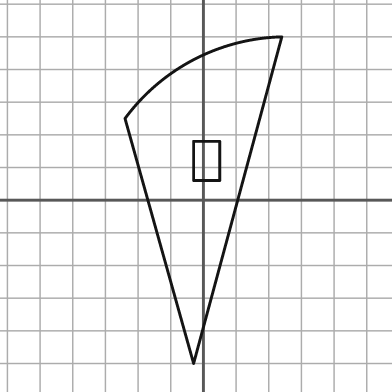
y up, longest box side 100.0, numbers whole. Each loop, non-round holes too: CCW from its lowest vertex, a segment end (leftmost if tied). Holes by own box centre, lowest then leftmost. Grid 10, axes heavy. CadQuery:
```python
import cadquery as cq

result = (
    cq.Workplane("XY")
    .moveTo(-3.0, -50.0)
    .lineTo(24.0, 50.0)
    .threePointArc((-3.0, 43.0), (-24.0, 25.0))
    .close()
    .moveTo(-3.0, 6.0)
    .lineTo(5.0, 6.0)
    .lineTo(5.0, 18.0)
    .lineTo(-3.0, 18.0)
    .close()
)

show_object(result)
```